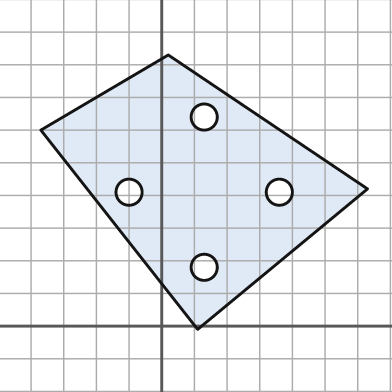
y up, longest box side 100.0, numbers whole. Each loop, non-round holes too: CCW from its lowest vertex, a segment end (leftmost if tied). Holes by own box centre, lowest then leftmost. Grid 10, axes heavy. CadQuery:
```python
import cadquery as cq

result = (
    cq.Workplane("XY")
    .moveTo(11.0, -1.0)
    .lineTo(63.0, 42.0)
    .lineTo(2.0, 83.0)
    .lineTo(-37.0, 60.0)
    .close()
    .moveTo(13.0, 18.0)
    .circle(4.0)
    .moveTo(-10.0, 41.0)
    .circle(4.0)
    .moveTo(36.0, 41.0)
    .circle(4.0)
    .moveTo(13.0, 64.0)
    .circle(4.0)
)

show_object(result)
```